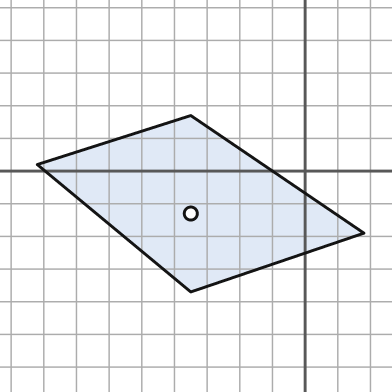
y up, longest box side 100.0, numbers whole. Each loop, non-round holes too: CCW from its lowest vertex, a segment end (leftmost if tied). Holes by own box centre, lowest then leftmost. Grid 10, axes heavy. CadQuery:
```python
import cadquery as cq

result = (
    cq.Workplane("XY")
    .moveTo(-35.0, -37.0)
    .lineTo(18.0, -19.0)
    .lineTo(-35.0, 17.0)
    .lineTo(-82.0, 2.0)
    .close()
    .moveTo(-35.0, -13.0)
    .circle(2.0)
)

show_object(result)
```